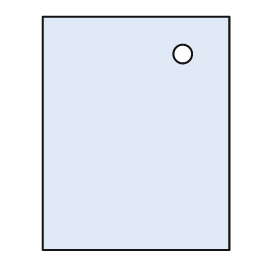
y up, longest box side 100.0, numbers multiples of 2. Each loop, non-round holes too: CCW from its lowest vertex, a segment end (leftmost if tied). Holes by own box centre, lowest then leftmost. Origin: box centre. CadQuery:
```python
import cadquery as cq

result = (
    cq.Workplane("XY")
    .moveTo(-40.0, -50.0)
    .lineTo(40.0, -50.0)
    .lineTo(40.0, 50.0)
    .lineTo(-40.0, 50.0)
    .close()
    .moveTo(20.0, 34.0)
    .circle(4.0)
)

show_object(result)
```